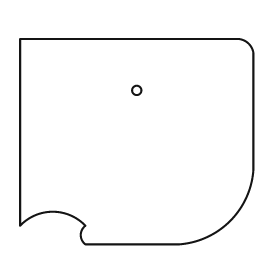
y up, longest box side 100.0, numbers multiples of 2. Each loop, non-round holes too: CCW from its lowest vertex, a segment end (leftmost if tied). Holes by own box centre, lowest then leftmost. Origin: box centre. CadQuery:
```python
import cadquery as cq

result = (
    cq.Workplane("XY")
    .moveTo(-22.0, -44.0)
    .lineTo(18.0, -44.0)
    .threePointArc((40.0, -34.0), (50.0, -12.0))
    .lineTo(50.0, 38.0)
    .threePointArc((48.0, 42.0), (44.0, 44.0))
    .lineTo(-50.0, 44.0)
    .lineTo(-50.0, -36.0)
    .threePointArc((-36.0, -30.0), (-22.0, -36.0))
    .threePointArc((-24.0, -40.0), (-22.0, -44.0))
    .close()
    .moveTo(0.0, 22.0)
    .circle(2.0)
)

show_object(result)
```